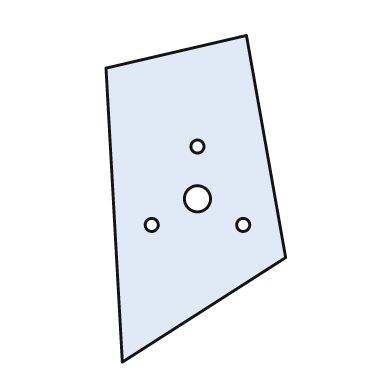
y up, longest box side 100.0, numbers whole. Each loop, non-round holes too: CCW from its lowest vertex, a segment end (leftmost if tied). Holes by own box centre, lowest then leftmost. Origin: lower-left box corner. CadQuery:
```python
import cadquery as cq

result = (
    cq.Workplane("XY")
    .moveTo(5.0, 0.0)
    .lineTo(55.0, 32.0)
    .lineTo(43.0, 100.0)
    .lineTo(0.0, 90.0)
    .close()
    .moveTo(14.0, 42.0)
    .circle(2.0)
    .moveTo(42.0, 42.0)
    .circle(2.0)
    .moveTo(28.0, 50.0)
    .circle(4.0)
    .moveTo(28.0, 66.0)
    .circle(2.0)
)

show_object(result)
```